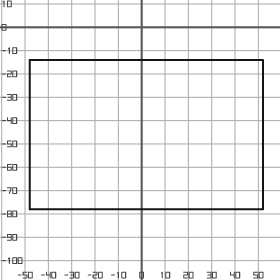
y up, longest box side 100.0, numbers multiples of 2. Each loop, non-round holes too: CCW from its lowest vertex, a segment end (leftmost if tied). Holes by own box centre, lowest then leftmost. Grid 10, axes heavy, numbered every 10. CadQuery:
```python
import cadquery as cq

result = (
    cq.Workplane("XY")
    .moveTo(-48.0, -78.0)
    .lineTo(52.0, -78.0)
    .lineTo(52.0, -14.0)
    .lineTo(-48.0, -14.0)
    .close()
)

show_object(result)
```